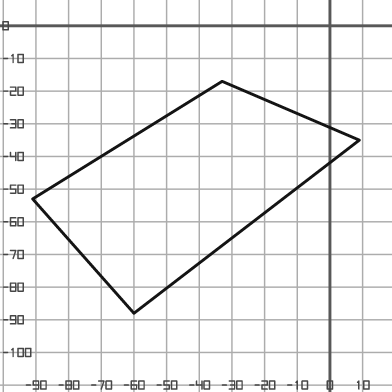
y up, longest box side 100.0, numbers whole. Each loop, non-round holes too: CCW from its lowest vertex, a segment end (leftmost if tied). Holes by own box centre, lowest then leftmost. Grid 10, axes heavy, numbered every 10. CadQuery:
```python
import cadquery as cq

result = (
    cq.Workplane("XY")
    .moveTo(-60.0, -88.0)
    .lineTo(9.0, -35.0)
    .lineTo(-33.0, -17.0)
    .lineTo(-91.0, -53.0)
    .close()
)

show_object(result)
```